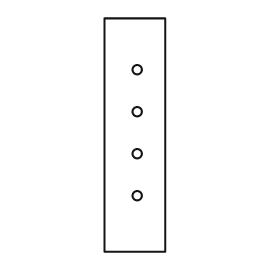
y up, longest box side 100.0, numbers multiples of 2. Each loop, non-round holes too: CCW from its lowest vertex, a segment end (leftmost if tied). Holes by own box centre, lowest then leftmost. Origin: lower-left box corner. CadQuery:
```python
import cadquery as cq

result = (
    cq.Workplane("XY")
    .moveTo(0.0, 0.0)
    .lineTo(26.0, 0.0)
    .lineTo(26.0, 100.0)
    .lineTo(0.0, 100.0)
    .close()
    .moveTo(14.0, 24.0)
    .circle(2.0)
    .moveTo(14.0, 42.0)
    .circle(2.0)
    .moveTo(14.0, 60.0)
    .circle(2.0)
    .moveTo(14.0, 78.0)
    .circle(2.0)
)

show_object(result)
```